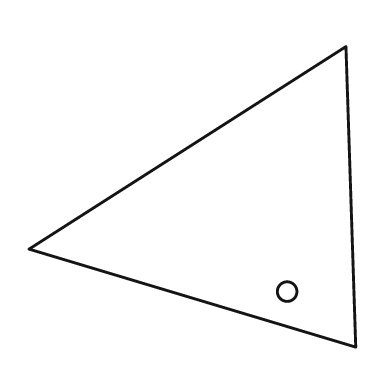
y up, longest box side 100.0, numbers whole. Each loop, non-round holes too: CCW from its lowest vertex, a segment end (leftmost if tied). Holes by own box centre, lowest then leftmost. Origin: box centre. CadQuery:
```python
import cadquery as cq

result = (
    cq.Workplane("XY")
    .moveTo(50.0, -46.0)
    .lineTo(47.0, 46.0)
    .lineTo(-50.0, -16.0)
    .close()
    .moveTo(29.0, -29.0)
    .circle(3.0)
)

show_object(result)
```